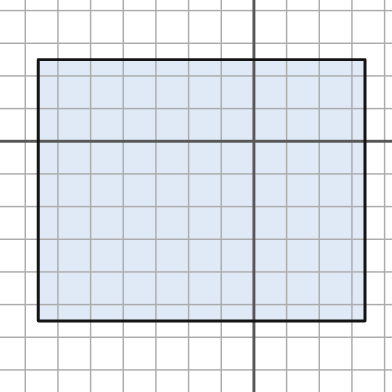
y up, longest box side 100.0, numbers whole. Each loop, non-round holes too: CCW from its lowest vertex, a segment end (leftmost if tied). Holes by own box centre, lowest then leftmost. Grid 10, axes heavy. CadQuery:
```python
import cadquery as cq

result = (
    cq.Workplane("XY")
    .moveTo(-66.0, -55.0)
    .lineTo(34.0, -55.0)
    .lineTo(34.0, 25.0)
    .lineTo(-66.0, 25.0)
    .close()
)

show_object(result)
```